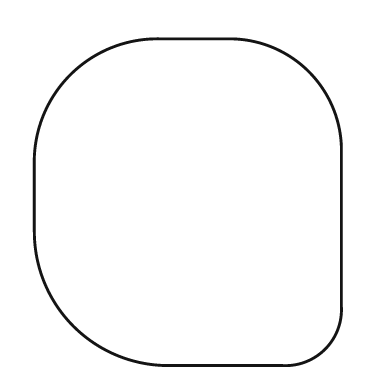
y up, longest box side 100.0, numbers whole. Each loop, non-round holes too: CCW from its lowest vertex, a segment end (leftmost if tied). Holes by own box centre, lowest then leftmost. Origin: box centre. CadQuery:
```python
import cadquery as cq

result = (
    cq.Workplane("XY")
    .moveTo(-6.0, -50.0)
    .lineTo(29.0, -50.0)
    .threePointArc((42.0, -45.0), (47.0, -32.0))
    .lineTo(47.0, 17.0)
    .threePointArc((37.0, 40.0), (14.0, 50.0))
    .lineTo(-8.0, 50.0)
    .threePointArc((-36.0, 39.0), (-47.0, 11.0))
    .lineTo(-47.0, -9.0)
    .threePointArc((-35.0, -38.0), (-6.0, -50.0))
    .close()
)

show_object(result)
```